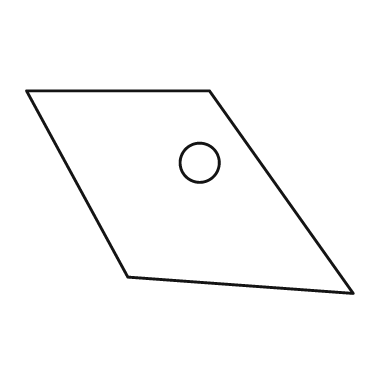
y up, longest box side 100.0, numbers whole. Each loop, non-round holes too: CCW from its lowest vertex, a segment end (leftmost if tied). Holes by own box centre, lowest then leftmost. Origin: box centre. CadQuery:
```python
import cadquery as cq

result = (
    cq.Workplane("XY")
    .moveTo(50.0, -31.0)
    .lineTo(6.0, 31.0)
    .lineTo(-50.0, 31.0)
    .lineTo(-19.0, -26.0)
    .close()
    .moveTo(3.0, 9.0)
    .circle(6.0)
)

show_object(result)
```